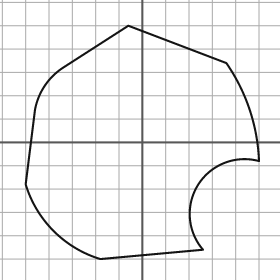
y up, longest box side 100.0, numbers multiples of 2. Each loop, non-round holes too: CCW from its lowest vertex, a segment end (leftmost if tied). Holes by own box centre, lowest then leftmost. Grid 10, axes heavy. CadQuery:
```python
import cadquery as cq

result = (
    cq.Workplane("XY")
    .moveTo(-18.0, -50.0)
    .lineTo(26.0, -46.0)
    .threePointArc((24.0, -18.0), (50.0, -8.0))
    .threePointArc((46.0, 14.0), (36.0, 34.0))
    .lineTo(-6.0, 50.0)
    .lineTo(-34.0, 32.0)
    .threePointArc((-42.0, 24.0), (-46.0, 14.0))
    .lineTo(-50.0, -18.0)
    .threePointArc((-38.0, -38.0), (-18.0, -50.0))
    .close()
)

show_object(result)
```